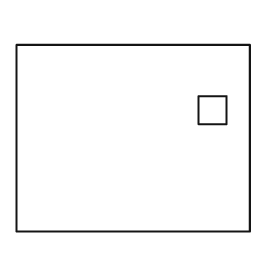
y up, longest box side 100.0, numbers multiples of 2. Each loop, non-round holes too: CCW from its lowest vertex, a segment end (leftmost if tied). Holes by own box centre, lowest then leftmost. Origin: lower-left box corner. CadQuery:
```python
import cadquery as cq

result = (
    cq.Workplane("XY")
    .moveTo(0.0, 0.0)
    .lineTo(100.0, 0.0)
    .lineTo(100.0, 80.0)
    .lineTo(0.0, 80.0)
    .close()
    .moveTo(78.0, 46.0)
    .lineTo(90.0, 46.0)
    .lineTo(90.0, 58.0)
    .lineTo(78.0, 58.0)
    .close()
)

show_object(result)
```